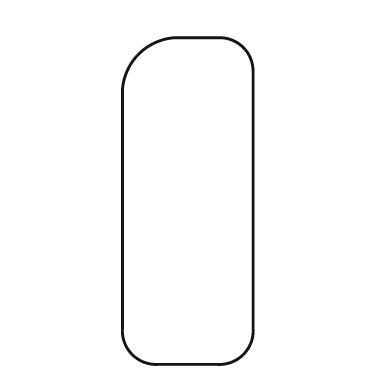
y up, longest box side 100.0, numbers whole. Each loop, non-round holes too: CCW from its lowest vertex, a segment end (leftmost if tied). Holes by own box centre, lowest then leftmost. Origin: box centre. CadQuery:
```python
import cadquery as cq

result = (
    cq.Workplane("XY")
    .moveTo(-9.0, -50.0)
    .lineTo(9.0, -50.0)
    .threePointArc((17.0, -47.0), (20.0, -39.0))
    .lineTo(20.0, 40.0)
    .threePointArc((17.0, 47.0), (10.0, 50.0))
    .lineTo(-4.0, 50.0)
    .threePointArc((-15.0, 45.0), (-20.0, 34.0))
    .lineTo(-20.0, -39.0)
    .threePointArc((-17.0, -47.0), (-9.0, -50.0))
    .close()
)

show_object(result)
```